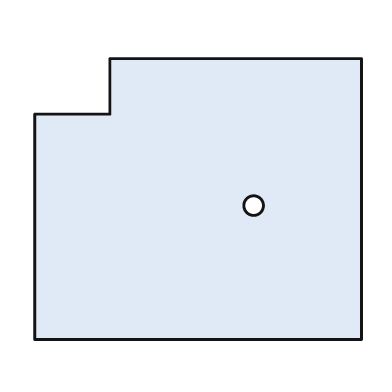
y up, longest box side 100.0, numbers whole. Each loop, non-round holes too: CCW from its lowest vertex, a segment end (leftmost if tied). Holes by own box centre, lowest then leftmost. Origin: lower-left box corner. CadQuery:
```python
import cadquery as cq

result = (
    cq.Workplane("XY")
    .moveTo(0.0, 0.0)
    .lineTo(100.0, 0.0)
    .lineTo(100.0, 86.0)
    .lineTo(23.0, 86.0)
    .lineTo(23.0, 69.0)
    .lineTo(0.0, 69.0)
    .close()
    .moveTo(67.0, 41.0)
    .circle(3.0)
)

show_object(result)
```